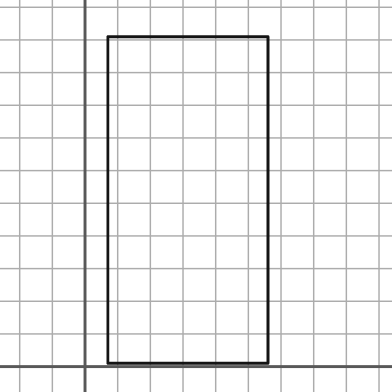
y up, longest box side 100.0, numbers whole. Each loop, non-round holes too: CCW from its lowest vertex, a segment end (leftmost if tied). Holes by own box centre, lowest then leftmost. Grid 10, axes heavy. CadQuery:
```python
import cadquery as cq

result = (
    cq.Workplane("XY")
    .moveTo(7.0, 1.0)
    .lineTo(56.0, 1.0)
    .lineTo(56.0, 101.0)
    .lineTo(7.0, 101.0)
    .close()
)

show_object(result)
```